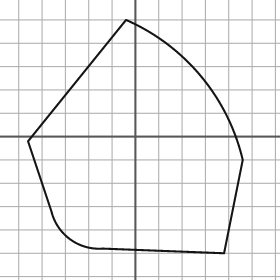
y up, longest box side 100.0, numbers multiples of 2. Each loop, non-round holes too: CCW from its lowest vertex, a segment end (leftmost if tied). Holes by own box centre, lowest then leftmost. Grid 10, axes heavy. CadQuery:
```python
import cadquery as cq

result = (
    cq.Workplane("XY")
    .moveTo(38.0, -50.0)
    .lineTo(46.0, -10.0)
    .threePointArc((28.0, 26.0), (-4.0, 50.0))
    .lineTo(-46.0, -2.0)
    .lineTo(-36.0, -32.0)
    .threePointArc((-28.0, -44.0), (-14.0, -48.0))
    .close()
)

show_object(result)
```